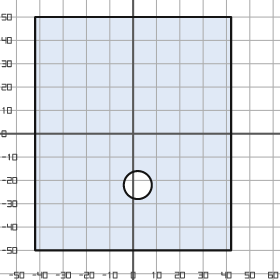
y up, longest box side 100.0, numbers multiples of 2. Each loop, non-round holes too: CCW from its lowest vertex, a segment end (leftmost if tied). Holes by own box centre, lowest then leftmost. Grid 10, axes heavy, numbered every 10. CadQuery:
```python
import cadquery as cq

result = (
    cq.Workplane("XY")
    .moveTo(-42.0, -50.0)
    .lineTo(42.0, -50.0)
    .lineTo(42.0, 50.0)
    .lineTo(-42.0, 50.0)
    .close()
    .moveTo(2.0, -22.0)
    .circle(6.0)
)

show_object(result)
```